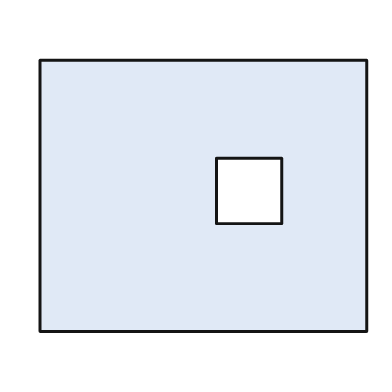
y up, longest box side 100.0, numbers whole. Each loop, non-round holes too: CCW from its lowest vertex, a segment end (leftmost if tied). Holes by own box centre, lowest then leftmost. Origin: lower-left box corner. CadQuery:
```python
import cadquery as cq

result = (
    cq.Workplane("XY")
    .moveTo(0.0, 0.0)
    .lineTo(100.0, 0.0)
    .lineTo(100.0, 83.0)
    .lineTo(0.0, 83.0)
    .close()
    .moveTo(54.0, 33.0)
    .lineTo(74.0, 33.0)
    .lineTo(74.0, 53.0)
    .lineTo(54.0, 53.0)
    .close()
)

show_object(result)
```